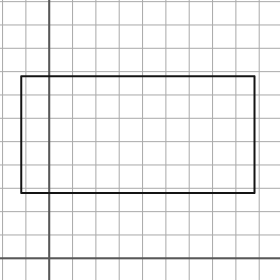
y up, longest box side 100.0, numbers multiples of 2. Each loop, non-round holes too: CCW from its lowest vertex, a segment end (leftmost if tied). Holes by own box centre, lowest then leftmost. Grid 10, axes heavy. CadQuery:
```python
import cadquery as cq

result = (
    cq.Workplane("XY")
    .moveTo(-12.0, 28.0)
    .lineTo(88.0, 28.0)
    .lineTo(88.0, 78.0)
    .lineTo(-12.0, 78.0)
    .close()
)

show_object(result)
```